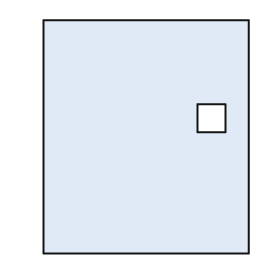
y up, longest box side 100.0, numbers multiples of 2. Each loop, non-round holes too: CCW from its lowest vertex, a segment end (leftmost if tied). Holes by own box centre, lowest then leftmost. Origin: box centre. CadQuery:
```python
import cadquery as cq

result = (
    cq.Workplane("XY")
    .moveTo(-44.0, -50.0)
    .lineTo(44.0, -50.0)
    .lineTo(44.0, 50.0)
    .lineTo(-44.0, 50.0)
    .close()
    .moveTo(22.0, 2.0)
    .lineTo(34.0, 2.0)
    .lineTo(34.0, 14.0)
    .lineTo(22.0, 14.0)
    .close()
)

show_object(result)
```